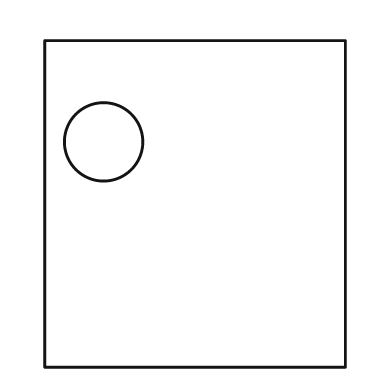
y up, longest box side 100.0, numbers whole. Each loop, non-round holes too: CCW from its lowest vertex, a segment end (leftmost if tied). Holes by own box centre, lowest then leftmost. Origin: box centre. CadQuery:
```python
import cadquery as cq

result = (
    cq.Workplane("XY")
    .moveTo(-46.0, -50.0)
    .lineTo(46.0, -50.0)
    .lineTo(46.0, 50.0)
    .lineTo(-46.0, 50.0)
    .close()
    .moveTo(-28.0, 19.0)
    .circle(12.0)
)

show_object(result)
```